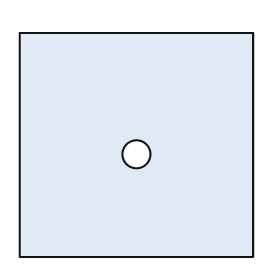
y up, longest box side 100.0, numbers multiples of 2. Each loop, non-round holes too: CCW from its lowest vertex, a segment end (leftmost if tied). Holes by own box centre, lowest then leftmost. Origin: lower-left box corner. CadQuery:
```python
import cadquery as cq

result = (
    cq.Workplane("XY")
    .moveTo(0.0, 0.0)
    .lineTo(100.0, 0.0)
    .lineTo(100.0, 96.0)
    .lineTo(0.0, 96.0)
    .close()
    .moveTo(50.0, 44.0)
    .circle(6.0)
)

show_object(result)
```